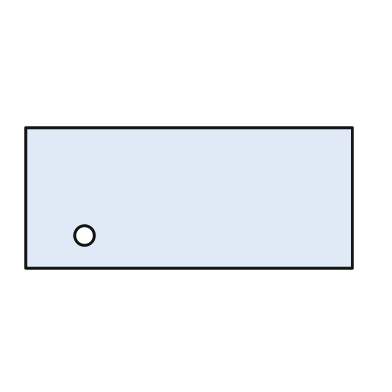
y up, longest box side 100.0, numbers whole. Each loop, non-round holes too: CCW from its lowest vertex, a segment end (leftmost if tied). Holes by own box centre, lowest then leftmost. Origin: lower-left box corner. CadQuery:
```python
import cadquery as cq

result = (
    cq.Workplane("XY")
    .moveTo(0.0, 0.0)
    .lineTo(100.0, 0.0)
    .lineTo(100.0, 43.0)
    .lineTo(0.0, 43.0)
    .close()
    .moveTo(18.0, 10.0)
    .circle(3.0)
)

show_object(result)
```